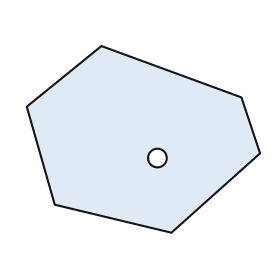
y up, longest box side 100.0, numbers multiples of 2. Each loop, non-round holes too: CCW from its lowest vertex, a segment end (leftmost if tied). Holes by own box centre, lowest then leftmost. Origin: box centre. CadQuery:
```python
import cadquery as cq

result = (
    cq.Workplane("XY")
    .moveTo(12.0, -40.0)
    .lineTo(50.0, -6.0)
    .lineTo(42.0, 18.0)
    .lineTo(-18.0, 40.0)
    .lineTo(-50.0, 14.0)
    .lineTo(-38.0, -28.0)
    .close()
    .moveTo(6.0, -8.0)
    .circle(4.0)
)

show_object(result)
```